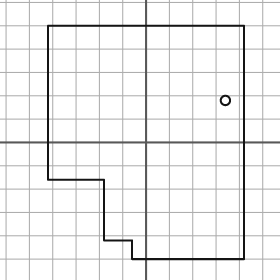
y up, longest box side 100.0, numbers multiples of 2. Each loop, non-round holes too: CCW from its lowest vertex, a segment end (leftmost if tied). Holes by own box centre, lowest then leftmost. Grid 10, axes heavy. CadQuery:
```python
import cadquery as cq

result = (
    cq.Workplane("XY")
    .moveTo(-6.0, -50.0)
    .lineTo(42.0, -50.0)
    .lineTo(42.0, 50.0)
    .lineTo(-42.0, 50.0)
    .lineTo(-42.0, -16.0)
    .lineTo(-18.0, -16.0)
    .lineTo(-18.0, -42.0)
    .lineTo(-6.0, -42.0)
    .close()
    .moveTo(34.0, 18.0)
    .circle(2.0)
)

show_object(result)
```